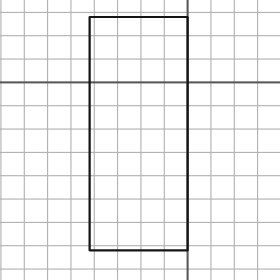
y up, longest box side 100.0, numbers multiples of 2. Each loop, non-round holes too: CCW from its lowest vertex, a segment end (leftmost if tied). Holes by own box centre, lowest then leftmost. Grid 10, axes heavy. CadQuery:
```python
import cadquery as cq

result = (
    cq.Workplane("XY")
    .moveTo(-42.0, -72.0)
    .lineTo(0.0, -72.0)
    .lineTo(0.0, 28.0)
    .lineTo(-42.0, 28.0)
    .close()
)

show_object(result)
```